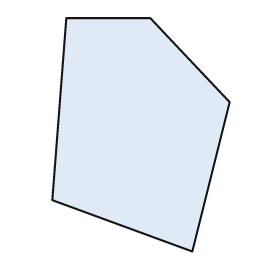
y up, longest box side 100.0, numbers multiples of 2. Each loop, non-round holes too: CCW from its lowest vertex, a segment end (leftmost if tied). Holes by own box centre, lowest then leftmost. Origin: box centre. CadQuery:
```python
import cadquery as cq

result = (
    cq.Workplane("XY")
    .moveTo(22.0, -50.0)
    .lineTo(38.0, 14.0)
    .lineTo(4.0, 50.0)
    .lineTo(-32.0, 50.0)
    .lineTo(-38.0, -28.0)
    .close()
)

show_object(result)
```